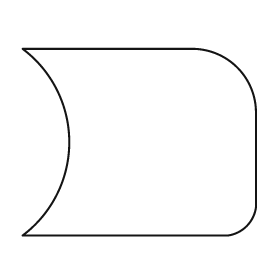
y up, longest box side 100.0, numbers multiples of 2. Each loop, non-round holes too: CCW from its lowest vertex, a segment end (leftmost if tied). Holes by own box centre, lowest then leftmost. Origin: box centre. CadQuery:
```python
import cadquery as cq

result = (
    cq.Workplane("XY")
    .moveTo(-50.0, -40.0)
    .lineTo(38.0, -40.0)
    .threePointArc((46.0, -36.0), (50.0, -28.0))
    .lineTo(50.0, 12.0)
    .threePointArc((42.0, 32.0), (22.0, 40.0))
    .lineTo(-50.0, 40.0)
    .threePointArc((-30.0, 0.0), (-50.0, -40.0))
    .close()
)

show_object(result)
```